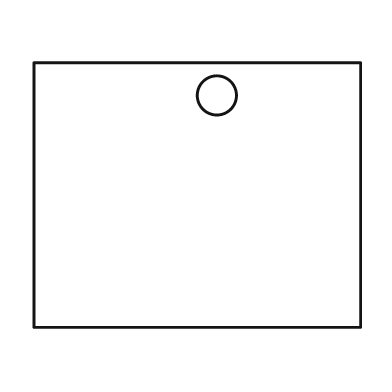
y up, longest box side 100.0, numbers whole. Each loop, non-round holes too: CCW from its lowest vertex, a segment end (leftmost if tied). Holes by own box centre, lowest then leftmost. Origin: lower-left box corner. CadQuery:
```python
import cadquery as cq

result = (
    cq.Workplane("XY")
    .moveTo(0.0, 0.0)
    .lineTo(100.0, 0.0)
    .lineTo(100.0, 81.0)
    .lineTo(0.0, 81.0)
    .close()
    .moveTo(56.0, 71.0)
    .circle(6.0)
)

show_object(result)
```